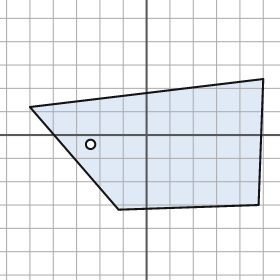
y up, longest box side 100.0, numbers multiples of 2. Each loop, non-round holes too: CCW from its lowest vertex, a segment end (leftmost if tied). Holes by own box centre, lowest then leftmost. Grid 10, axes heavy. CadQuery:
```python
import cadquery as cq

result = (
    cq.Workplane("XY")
    .moveTo(-12.0, -32.0)
    .lineTo(48.0, -30.0)
    .lineTo(50.0, 24.0)
    .lineTo(-50.0, 12.0)
    .close()
    .moveTo(-24.0, -4.0)
    .circle(2.0)
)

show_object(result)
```